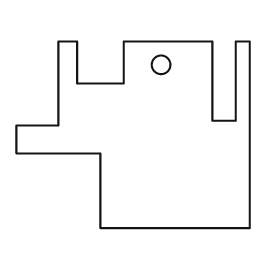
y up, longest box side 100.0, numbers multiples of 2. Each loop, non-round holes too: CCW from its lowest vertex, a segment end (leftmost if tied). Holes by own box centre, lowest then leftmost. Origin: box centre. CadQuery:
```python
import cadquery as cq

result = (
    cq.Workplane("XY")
    .moveTo(-14.0, -40.0)
    .lineTo(50.0, -40.0)
    .lineTo(50.0, 40.0)
    .lineTo(44.0, 40.0)
    .lineTo(44.0, 6.0)
    .lineTo(34.0, 6.0)
    .lineTo(34.0, 40.0)
    .lineTo(-4.0, 40.0)
    .lineTo(-4.0, 22.0)
    .lineTo(-24.0, 22.0)
    .lineTo(-24.0, 40.0)
    .lineTo(-32.0, 40.0)
    .lineTo(-32.0, 4.0)
    .lineTo(-50.0, 4.0)
    .lineTo(-50.0, -8.0)
    .lineTo(-14.0, -8.0)
    .close()
    .moveTo(12.0, 30.0)
    .circle(4.0)
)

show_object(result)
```